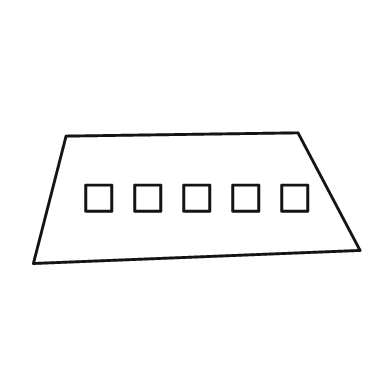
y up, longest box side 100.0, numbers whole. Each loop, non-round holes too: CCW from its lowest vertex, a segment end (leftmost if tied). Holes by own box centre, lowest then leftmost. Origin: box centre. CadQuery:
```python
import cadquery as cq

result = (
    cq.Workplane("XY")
    .moveTo(-50.0, -20.0)
    .lineTo(50.0, -16.0)
    .lineTo(31.0, 20.0)
    .lineTo(-40.0, 19.0)
    .close()
    .moveTo(-34.0, -4.0)
    .lineTo(-26.0, -4.0)
    .lineTo(-26.0, 4.0)
    .lineTo(-34.0, 4.0)
    .close()
    .moveTo(-19.0, -4.0)
    .lineTo(-11.0, -4.0)
    .lineTo(-11.0, 4.0)
    .lineTo(-19.0, 4.0)
    .close()
    .moveTo(-4.0, -4.0)
    .lineTo(4.0, -4.0)
    .lineTo(4.0, 4.0)
    .lineTo(-4.0, 4.0)
    .close()
    .moveTo(11.0, -4.0)
    .lineTo(19.0, -4.0)
    .lineTo(19.0, 4.0)
    .lineTo(11.0, 4.0)
    .close()
    .moveTo(26.0, -4.0)
    .lineTo(34.0, -4.0)
    .lineTo(34.0, 4.0)
    .lineTo(26.0, 4.0)
    .close()
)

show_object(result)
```